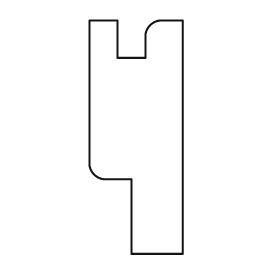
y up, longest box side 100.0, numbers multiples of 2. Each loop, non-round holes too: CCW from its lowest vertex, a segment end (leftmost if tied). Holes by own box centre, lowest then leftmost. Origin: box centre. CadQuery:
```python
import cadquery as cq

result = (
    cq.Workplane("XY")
    .moveTo(-2.0, -50.0)
    .lineTo(20.0, -50.0)
    .lineTo(20.0, 50.0)
    .lineTo(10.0, 50.0)
    .threePointArc((6.0, 48.0), (4.0, 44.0))
    .lineTo(4.0, 34.0)
    .lineTo(-8.0, 34.0)
    .lineTo(-8.0, 50.0)
    .lineTo(-20.0, 50.0)
    .lineTo(-20.0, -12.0)
    .threePointArc((-18.0, -16.0), (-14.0, -18.0))
    .lineTo(-2.0, -18.0)
    .close()
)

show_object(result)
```